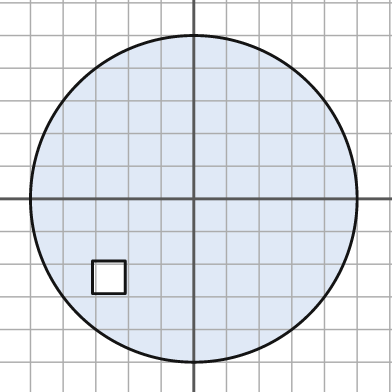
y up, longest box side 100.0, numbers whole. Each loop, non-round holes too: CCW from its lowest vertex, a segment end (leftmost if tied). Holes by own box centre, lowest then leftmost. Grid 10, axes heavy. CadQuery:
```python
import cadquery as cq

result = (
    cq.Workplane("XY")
    .moveTo(0.0, 0.0)
    .circle(50.0)
    .moveTo(-31.0, -29.0)
    .lineTo(-21.0, -29.0)
    .lineTo(-21.0, -19.0)
    .lineTo(-31.0, -19.0)
    .close()
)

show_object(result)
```